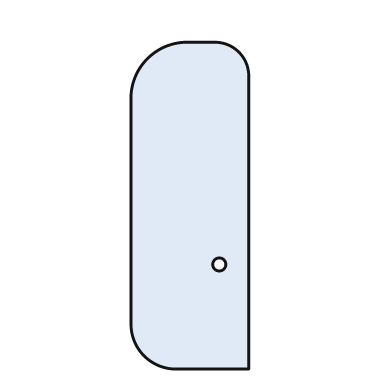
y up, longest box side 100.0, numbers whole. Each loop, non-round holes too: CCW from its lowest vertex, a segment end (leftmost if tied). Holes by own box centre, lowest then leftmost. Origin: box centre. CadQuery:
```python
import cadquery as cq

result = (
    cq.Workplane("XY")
    .moveTo(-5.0, -50.0)
    .lineTo(18.0, -50.0)
    .lineTo(18.0, 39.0)
    .threePointArc((15.0, 47.0), (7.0, 50.0))
    .lineTo(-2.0, 50.0)
    .threePointArc((-13.0, 45.0), (-18.0, 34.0))
    .lineTo(-18.0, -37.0)
    .threePointArc((-14.0, -46.0), (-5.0, -50.0))
    .close()
    .moveTo(9.0, -18.0)
    .circle(2.0)
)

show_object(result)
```